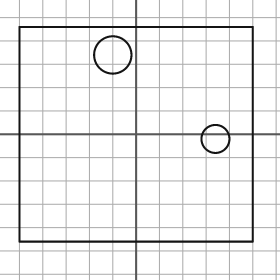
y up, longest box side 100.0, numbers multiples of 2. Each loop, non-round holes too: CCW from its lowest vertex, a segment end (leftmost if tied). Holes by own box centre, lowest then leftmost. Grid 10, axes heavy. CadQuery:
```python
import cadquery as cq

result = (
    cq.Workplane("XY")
    .moveTo(-50.0, -46.0)
    .lineTo(50.0, -46.0)
    .lineTo(50.0, 46.0)
    .lineTo(-50.0, 46.0)
    .close()
    .moveTo(34.0, -2.0)
    .circle(6.0)
    .moveTo(-10.0, 34.0)
    .circle(8.0)
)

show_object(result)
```